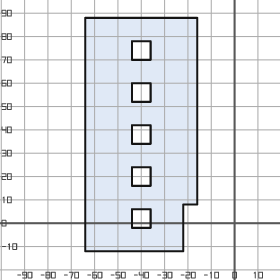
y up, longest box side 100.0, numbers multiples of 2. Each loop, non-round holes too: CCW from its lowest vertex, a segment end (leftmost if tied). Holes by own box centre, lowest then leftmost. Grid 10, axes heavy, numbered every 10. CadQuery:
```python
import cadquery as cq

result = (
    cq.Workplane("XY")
    .moveTo(-64.0, -12.0)
    .lineTo(-22.0, -12.0)
    .lineTo(-22.0, 8.0)
    .lineTo(-16.0, 8.0)
    .lineTo(-16.0, 88.0)
    .lineTo(-64.0, 88.0)
    .close()
    .moveTo(-44.0, -2.0)
    .lineTo(-36.0, -2.0)
    .lineTo(-36.0, 6.0)
    .lineTo(-44.0, 6.0)
    .close()
    .moveTo(-44.0, 16.0)
    .lineTo(-36.0, 16.0)
    .lineTo(-36.0, 24.0)
    .lineTo(-44.0, 24.0)
    .close()
    .moveTo(-44.0, 34.0)
    .lineTo(-36.0, 34.0)
    .lineTo(-36.0, 42.0)
    .lineTo(-44.0, 42.0)
    .close()
    .moveTo(-44.0, 52.0)
    .lineTo(-36.0, 52.0)
    .lineTo(-36.0, 60.0)
    .lineTo(-44.0, 60.0)
    .close()
    .moveTo(-44.0, 70.0)
    .lineTo(-36.0, 70.0)
    .lineTo(-36.0, 78.0)
    .lineTo(-44.0, 78.0)
    .close()
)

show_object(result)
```